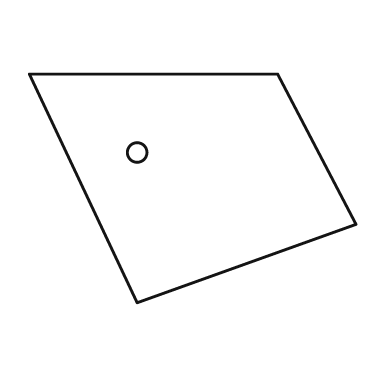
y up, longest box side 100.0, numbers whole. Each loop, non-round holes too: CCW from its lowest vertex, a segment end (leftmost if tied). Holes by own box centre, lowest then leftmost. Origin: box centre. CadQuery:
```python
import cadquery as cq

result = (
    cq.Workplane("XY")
    .moveTo(-17.0, -35.0)
    .lineTo(50.0, -11.0)
    .lineTo(26.0, 35.0)
    .lineTo(-50.0, 35.0)
    .close()
    .moveTo(-17.0, 11.0)
    .circle(3.0)
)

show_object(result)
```